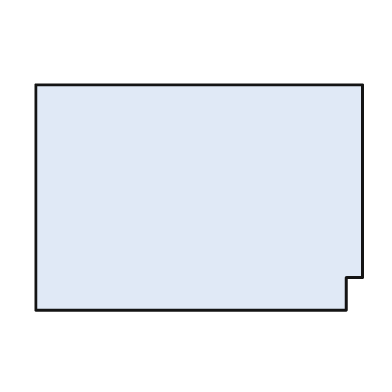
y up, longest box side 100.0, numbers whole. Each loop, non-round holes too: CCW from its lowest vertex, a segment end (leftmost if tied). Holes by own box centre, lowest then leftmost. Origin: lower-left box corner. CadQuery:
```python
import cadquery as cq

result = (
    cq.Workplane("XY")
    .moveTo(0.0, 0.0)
    .lineTo(95.0, 0.0)
    .lineTo(95.0, 10.0)
    .lineTo(100.0, 10.0)
    .lineTo(100.0, 69.0)
    .lineTo(0.0, 69.0)
    .close()
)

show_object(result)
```